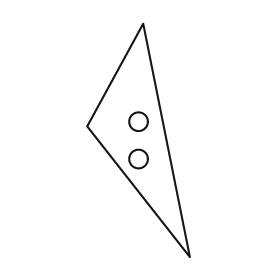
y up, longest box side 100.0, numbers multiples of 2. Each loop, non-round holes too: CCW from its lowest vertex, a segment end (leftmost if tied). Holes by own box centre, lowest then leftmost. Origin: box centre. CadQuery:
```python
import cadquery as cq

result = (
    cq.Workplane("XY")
    .moveTo(22.0, -50.0)
    .lineTo(2.0, 50.0)
    .lineTo(-22.0, 6.0)
    .close()
    .moveTo(0.0, -8.0)
    .circle(4.0)
    .moveTo(0.0, 8.0)
    .circle(4.0)
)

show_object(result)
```